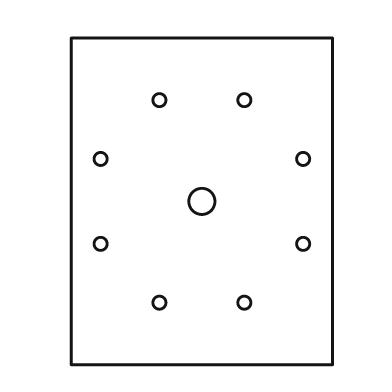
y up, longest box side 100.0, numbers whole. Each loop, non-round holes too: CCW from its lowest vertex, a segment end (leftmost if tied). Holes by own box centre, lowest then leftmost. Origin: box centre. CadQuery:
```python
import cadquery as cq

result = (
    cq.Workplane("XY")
    .moveTo(-40.0, -50.0)
    .lineTo(40.0, -50.0)
    .lineTo(40.0, 50.0)
    .lineTo(-40.0, 50.0)
    .close()
    .moveTo(-13.0, -31.0)
    .circle(2.0)
    .moveTo(13.0, -31.0)
    .circle(2.0)
    .moveTo(-31.0, -13.0)
    .circle(2.0)
    .moveTo(31.0, -13.0)
    .circle(2.0)
    .moveTo(0.0, 0.0)
    .circle(4.0)
    .moveTo(-31.0, 13.0)
    .circle(2.0)
    .moveTo(31.0, 13.0)
    .circle(2.0)
    .moveTo(-13.0, 31.0)
    .circle(2.0)
    .moveTo(13.0, 31.0)
    .circle(2.0)
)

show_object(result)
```